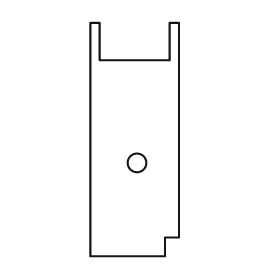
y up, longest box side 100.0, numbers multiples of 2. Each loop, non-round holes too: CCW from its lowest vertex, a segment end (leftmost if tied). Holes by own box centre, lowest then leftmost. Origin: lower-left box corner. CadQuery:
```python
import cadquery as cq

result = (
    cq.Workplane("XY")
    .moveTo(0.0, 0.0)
    .lineTo(32.0, 0.0)
    .lineTo(32.0, 8.0)
    .lineTo(38.0, 8.0)
    .lineTo(38.0, 100.0)
    .lineTo(34.0, 100.0)
    .lineTo(34.0, 84.0)
    .lineTo(4.0, 84.0)
    .lineTo(4.0, 100.0)
    .lineTo(0.0, 100.0)
    .close()
    .moveTo(20.0, 40.0)
    .circle(4.0)
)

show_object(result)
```